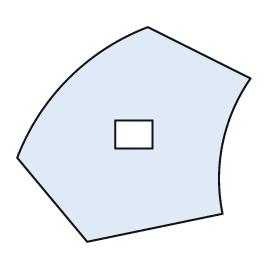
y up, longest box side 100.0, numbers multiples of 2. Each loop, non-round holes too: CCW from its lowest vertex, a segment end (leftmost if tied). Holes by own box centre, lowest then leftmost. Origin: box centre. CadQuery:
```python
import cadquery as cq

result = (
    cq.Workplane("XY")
    .moveTo(-20.0, -46.0)
    .lineTo(38.0, -34.0)
    .threePointArc((38.0, -4.0), (50.0, 24.0))
    .lineTo(6.0, 46.0)
    .threePointArc((-28.0, 24.0), (-50.0, -10.0))
    .close()
    .moveTo(-8.0, -6.0)
    .lineTo(8.0, -6.0)
    .lineTo(8.0, 6.0)
    .lineTo(-8.0, 6.0)
    .close()
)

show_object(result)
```